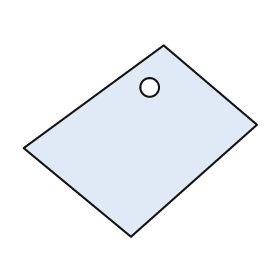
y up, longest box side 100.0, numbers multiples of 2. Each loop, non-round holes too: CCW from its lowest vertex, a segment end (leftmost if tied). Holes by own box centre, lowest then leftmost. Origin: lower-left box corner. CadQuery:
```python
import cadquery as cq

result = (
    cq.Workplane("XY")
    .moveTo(46.0, 0.0)
    .lineTo(100.0, 48.0)
    .lineTo(60.0, 82.0)
    .lineTo(0.0, 38.0)
    .close()
    .moveTo(54.0, 64.0)
    .circle(4.0)
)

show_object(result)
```